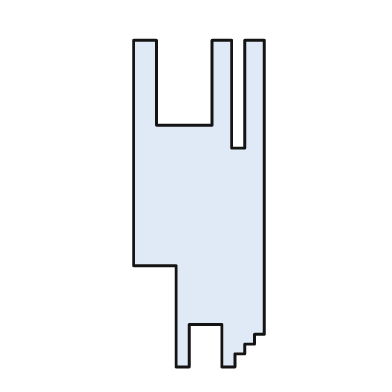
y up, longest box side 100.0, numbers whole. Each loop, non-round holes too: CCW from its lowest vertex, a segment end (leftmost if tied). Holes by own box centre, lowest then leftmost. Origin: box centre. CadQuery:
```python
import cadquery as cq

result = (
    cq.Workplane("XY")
    .moveTo(-7.0, -50.0)
    .lineTo(-3.0, -50.0)
    .lineTo(-3.0, -37.0)
    .lineTo(7.0, -37.0)
    .lineTo(7.0, -50.0)
    .lineTo(11.0, -50.0)
    .lineTo(11.0, -46.0)
    .lineTo(14.0, -46.0)
    .lineTo(14.0, -43.0)
    .lineTo(17.0, -43.0)
    .lineTo(17.0, -40.0)
    .lineTo(20.0, -40.0)
    .lineTo(20.0, 50.0)
    .lineTo(14.0, 50.0)
    .lineTo(14.0, 17.0)
    .lineTo(10.0, 17.0)
    .lineTo(10.0, 50.0)
    .lineTo(4.0, 50.0)
    .lineTo(4.0, 24.0)
    .lineTo(-13.0, 24.0)
    .lineTo(-13.0, 50.0)
    .lineTo(-20.0, 50.0)
    .lineTo(-20.0, -19.0)
    .lineTo(-7.0, -19.0)
    .close()
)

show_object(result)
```